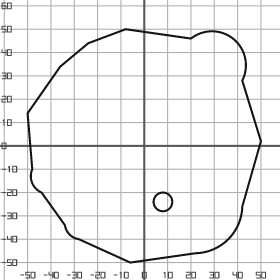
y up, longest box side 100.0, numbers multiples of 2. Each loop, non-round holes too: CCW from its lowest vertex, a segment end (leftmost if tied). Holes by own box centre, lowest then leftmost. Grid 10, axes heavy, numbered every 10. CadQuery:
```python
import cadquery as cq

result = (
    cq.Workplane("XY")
    .moveTo(-6.0, -50.0)
    .lineTo(22.0, -46.0)
    .threePointArc((36.0, -40.0), (42.0, -26.0))
    .lineTo(50.0, 2.0)
    .lineTo(42.0, 28.0)
    .threePointArc((38.0, 46.0), (20.0, 46.0))
    .lineTo(-8.0, 50.0)
    .lineTo(-24.0, 44.0)
    .lineTo(-36.0, 34.0)
    .lineTo(-50.0, 14.0)
    .lineTo(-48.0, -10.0)
    .threePointArc((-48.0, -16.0), (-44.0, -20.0))
    .lineTo(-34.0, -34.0)
    .threePointArc((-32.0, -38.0), (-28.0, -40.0))
    .close()
    .moveTo(8.0, -24.0)
    .circle(4.0)
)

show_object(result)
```